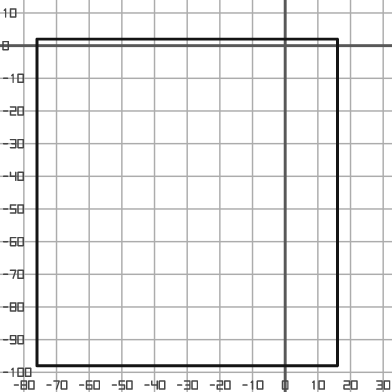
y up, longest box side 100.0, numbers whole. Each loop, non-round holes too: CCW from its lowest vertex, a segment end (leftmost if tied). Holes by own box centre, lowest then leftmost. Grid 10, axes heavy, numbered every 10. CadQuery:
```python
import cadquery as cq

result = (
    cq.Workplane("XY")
    .moveTo(-76.0, -98.0)
    .lineTo(16.0, -98.0)
    .lineTo(16.0, 2.0)
    .lineTo(-76.0, 2.0)
    .close()
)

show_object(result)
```